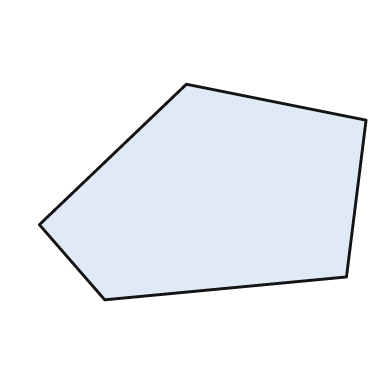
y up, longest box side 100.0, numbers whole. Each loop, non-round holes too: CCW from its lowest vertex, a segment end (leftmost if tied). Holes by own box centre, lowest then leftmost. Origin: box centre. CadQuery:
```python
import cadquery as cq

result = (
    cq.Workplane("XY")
    .moveTo(-30.0, -33.0)
    .lineTo(44.0, -26.0)
    .lineTo(50.0, 22.0)
    .lineTo(-5.0, 33.0)
    .lineTo(-50.0, -10.0)
    .close()
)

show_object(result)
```